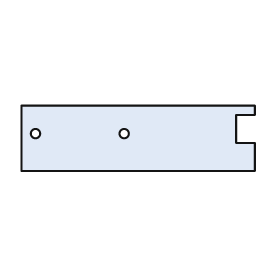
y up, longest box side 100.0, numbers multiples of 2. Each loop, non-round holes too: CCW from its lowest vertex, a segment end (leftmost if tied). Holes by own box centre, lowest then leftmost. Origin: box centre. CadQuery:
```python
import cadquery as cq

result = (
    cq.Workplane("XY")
    .moveTo(-50.0, -14.0)
    .lineTo(50.0, -14.0)
    .lineTo(50.0, -2.0)
    .lineTo(42.0, -2.0)
    .lineTo(42.0, 10.0)
    .lineTo(50.0, 10.0)
    .lineTo(50.0, 14.0)
    .lineTo(-50.0, 14.0)
    .close()
    .moveTo(-44.0, 2.0)
    .circle(2.0)
    .moveTo(-6.0, 2.0)
    .circle(2.0)
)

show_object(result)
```